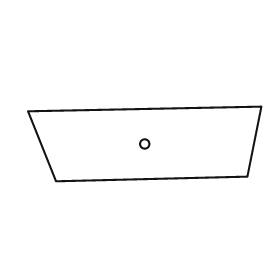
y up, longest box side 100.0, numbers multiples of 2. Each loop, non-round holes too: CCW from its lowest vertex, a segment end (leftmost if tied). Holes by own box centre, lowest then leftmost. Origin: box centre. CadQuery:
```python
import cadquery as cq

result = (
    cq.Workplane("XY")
    .moveTo(-38.0, -16.0)
    .lineTo(44.0, -14.0)
    .lineTo(50.0, 16.0)
    .lineTo(-50.0, 14.0)
    .close()
    .moveTo(0.0, 0.0)
    .circle(2.0)
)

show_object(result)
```